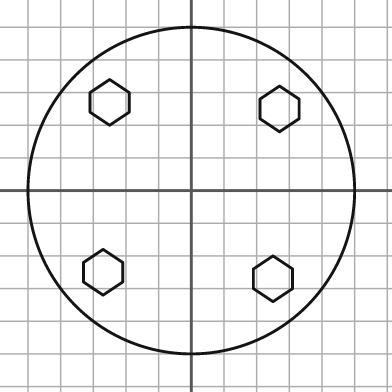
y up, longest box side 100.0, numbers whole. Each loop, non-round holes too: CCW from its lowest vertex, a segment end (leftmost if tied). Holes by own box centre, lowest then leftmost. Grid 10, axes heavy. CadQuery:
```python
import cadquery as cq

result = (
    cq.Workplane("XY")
    .moveTo(0.0, 0.0)
    .circle(50.0)
    .moveTo(25.0, -34.0)
    .lineTo(31.0, -30.0)
    .lineTo(31.0, -24.0)
    .lineTo(25.0, -20.0)
    .lineTo(19.0, -24.0)
    .lineTo(19.0, -30.0)
    .close()
    .moveTo(-27.0, -32.0)
    .lineTo(-21.0, -28.0)
    .lineTo(-21.0, -22.0)
    .lineTo(-27.0, -18.0)
    .lineTo(-33.0, -22.0)
    .lineTo(-33.0, -28.0)
    .close()
    .moveTo(27.0, 18.0)
    .lineTo(33.0, 22.0)
    .lineTo(33.0, 28.0)
    .lineTo(27.0, 32.0)
    .lineTo(21.0, 28.0)
    .lineTo(21.0, 22.0)
    .close()
    .moveTo(-25.0, 20.0)
    .lineTo(-19.0, 24.0)
    .lineTo(-19.0, 30.0)
    .lineTo(-25.0, 34.0)
    .lineTo(-31.0, 30.0)
    .lineTo(-31.0, 24.0)
    .close()
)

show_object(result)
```